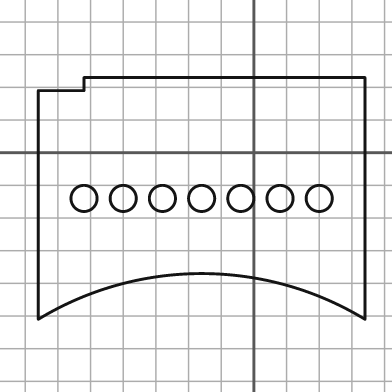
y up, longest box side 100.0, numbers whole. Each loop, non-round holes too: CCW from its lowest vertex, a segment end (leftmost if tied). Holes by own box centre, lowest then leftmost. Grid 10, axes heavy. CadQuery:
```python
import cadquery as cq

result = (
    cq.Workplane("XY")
    .moveTo(-66.0, -51.0)
    .threePointArc((-16.0, -37.0), (34.0, -51.0))
    .lineTo(34.0, 23.0)
    .lineTo(-52.0, 23.0)
    .lineTo(-52.0, 19.0)
    .lineTo(-66.0, 19.0)
    .close()
    .moveTo(-52.0, -14.0)
    .circle(4.0)
    .moveTo(-40.0, -14.0)
    .circle(4.0)
    .moveTo(-28.0, -14.0)
    .circle(4.0)
    .moveTo(-16.0, -14.0)
    .circle(4.0)
    .moveTo(-4.0, -14.0)
    .circle(4.0)
    .moveTo(8.0, -14.0)
    .circle(4.0)
    .moveTo(20.0, -14.0)
    .circle(4.0)
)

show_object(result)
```